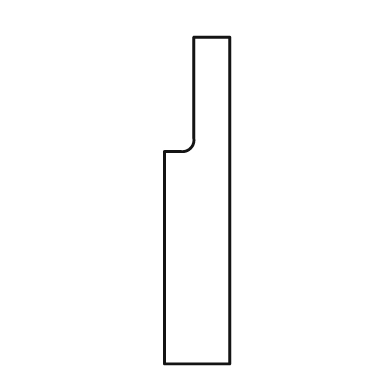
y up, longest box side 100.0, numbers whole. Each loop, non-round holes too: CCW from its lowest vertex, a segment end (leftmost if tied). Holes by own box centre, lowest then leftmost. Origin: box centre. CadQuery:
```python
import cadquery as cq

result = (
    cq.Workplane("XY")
    .moveTo(-10.0, -50.0)
    .lineTo(10.0, -50.0)
    .lineTo(10.0, 50.0)
    .lineTo(-1.0, 50.0)
    .lineTo(-1.0, 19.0)
    .threePointArc((-2.0, 16.0), (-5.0, 15.0))
    .lineTo(-10.0, 15.0)
    .close()
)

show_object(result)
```